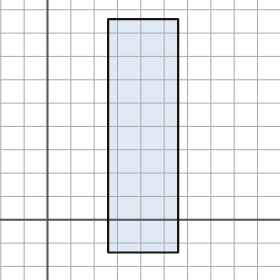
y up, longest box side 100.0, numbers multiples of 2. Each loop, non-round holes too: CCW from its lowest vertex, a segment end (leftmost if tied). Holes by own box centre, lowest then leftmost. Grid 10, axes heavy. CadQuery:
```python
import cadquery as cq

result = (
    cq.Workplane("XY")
    .moveTo(26.0, -14.0)
    .lineTo(56.0, -14.0)
    .lineTo(56.0, 86.0)
    .lineTo(26.0, 86.0)
    .close()
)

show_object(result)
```